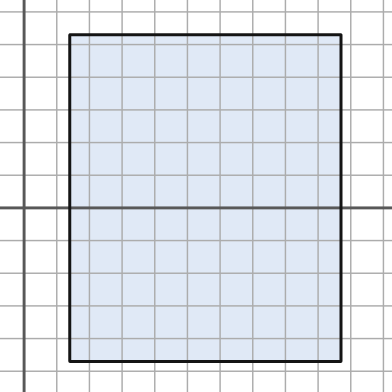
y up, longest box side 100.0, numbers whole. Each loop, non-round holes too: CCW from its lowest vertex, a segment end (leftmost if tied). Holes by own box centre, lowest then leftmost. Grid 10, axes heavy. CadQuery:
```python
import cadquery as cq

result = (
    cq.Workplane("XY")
    .moveTo(14.0, -47.0)
    .lineTo(97.0, -47.0)
    .lineTo(97.0, 53.0)
    .lineTo(14.0, 53.0)
    .close()
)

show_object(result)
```